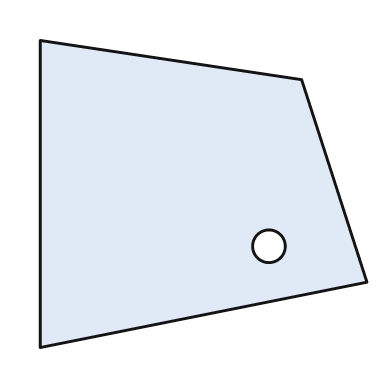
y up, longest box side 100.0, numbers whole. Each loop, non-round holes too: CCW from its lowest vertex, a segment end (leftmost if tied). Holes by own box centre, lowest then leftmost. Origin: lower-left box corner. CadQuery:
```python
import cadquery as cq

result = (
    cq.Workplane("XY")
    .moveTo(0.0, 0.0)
    .lineTo(100.0, 20.0)
    .lineTo(80.0, 82.0)
    .lineTo(0.0, 94.0)
    .close()
    .moveTo(70.0, 31.0)
    .circle(5.0)
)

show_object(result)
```